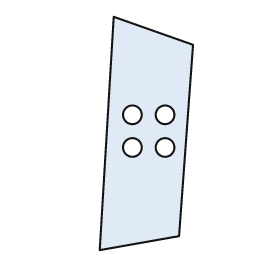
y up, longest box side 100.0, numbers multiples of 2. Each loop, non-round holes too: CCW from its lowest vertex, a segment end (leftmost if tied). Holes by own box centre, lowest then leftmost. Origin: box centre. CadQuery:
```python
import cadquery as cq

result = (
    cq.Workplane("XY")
    .moveTo(-20.0, -50.0)
    .lineTo(14.0, -44.0)
    .lineTo(20.0, 38.0)
    .lineTo(-14.0, 50.0)
    .close()
    .moveTo(-6.0, -6.0)
    .circle(4.0)
    .moveTo(8.0, -6.0)
    .circle(4.0)
    .moveTo(-6.0, 8.0)
    .circle(4.0)
    .moveTo(8.0, 8.0)
    .circle(4.0)
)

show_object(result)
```